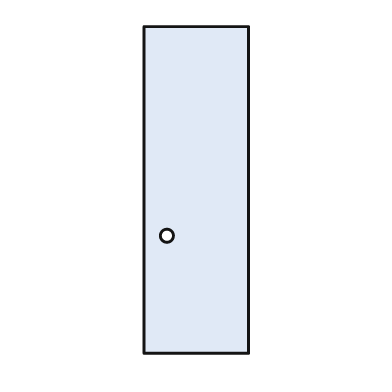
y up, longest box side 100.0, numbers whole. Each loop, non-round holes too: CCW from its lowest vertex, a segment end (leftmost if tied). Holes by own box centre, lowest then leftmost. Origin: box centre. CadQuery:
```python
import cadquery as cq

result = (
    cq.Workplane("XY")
    .moveTo(-16.0, -50.0)
    .lineTo(16.0, -50.0)
    .lineTo(16.0, 50.0)
    .lineTo(-16.0, 50.0)
    .close()
    .moveTo(-9.0, -14.0)
    .circle(2.0)
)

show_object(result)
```